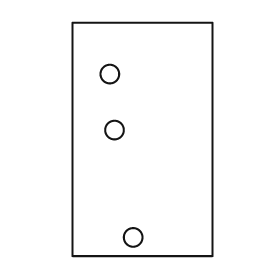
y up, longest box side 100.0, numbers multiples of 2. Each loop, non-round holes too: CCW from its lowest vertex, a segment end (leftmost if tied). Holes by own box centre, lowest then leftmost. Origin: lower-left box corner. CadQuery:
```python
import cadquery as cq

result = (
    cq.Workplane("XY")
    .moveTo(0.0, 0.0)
    .lineTo(60.0, 0.0)
    .lineTo(60.0, 100.0)
    .lineTo(0.0, 100.0)
    .close()
    .moveTo(26.0, 8.0)
    .circle(4.0)
    .moveTo(18.0, 54.0)
    .circle(4.0)
    .moveTo(16.0, 78.0)
    .circle(4.0)
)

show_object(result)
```